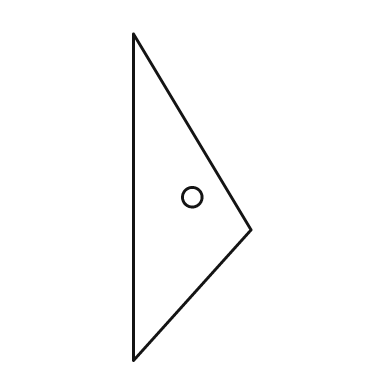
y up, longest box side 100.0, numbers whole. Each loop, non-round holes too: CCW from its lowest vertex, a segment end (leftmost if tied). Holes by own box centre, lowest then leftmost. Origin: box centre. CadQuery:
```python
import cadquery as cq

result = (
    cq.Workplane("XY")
    .moveTo(-18.0, -50.0)
    .lineTo(18.0, -10.0)
    .lineTo(-18.0, 50.0)
    .close()
    .moveTo(0.0, 0.0)
    .circle(3.0)
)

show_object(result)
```